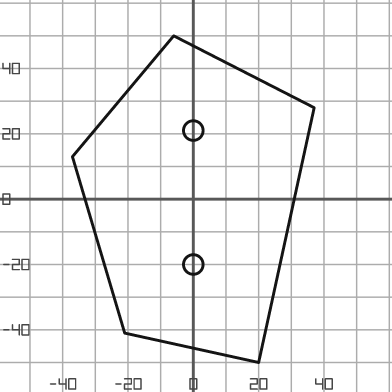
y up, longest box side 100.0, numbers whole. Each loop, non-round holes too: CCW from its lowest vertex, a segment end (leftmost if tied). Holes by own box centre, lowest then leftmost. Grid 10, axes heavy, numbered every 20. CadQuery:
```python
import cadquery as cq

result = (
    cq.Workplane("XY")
    .moveTo(20.0, -50.0)
    .lineTo(37.0, 28.0)
    .lineTo(-6.0, 50.0)
    .lineTo(-37.0, 13.0)
    .lineTo(-21.0, -41.0)
    .close()
    .moveTo(0.0, -20.0)
    .circle(3.0)
    .moveTo(0.0, 21.0)
    .circle(3.0)
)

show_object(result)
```